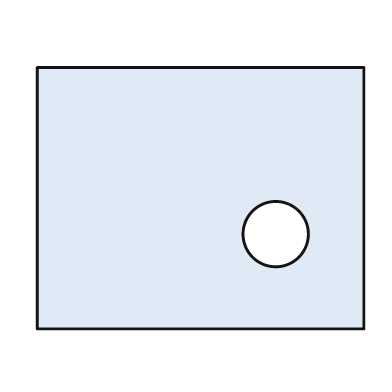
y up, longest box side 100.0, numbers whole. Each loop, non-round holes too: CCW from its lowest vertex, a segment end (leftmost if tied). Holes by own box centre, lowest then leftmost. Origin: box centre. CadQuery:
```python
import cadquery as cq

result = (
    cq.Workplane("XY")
    .moveTo(-50.0, -40.0)
    .lineTo(50.0, -40.0)
    .lineTo(50.0, 40.0)
    .lineTo(-50.0, 40.0)
    .close()
    .moveTo(23.0, -11.0)
    .circle(10.0)
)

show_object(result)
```